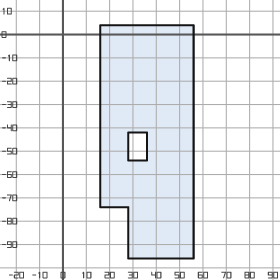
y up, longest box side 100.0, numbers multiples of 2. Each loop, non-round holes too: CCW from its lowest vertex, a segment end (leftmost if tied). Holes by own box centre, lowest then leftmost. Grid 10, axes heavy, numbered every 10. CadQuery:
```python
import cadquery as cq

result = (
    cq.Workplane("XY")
    .moveTo(28.0, -96.0)
    .lineTo(56.0, -96.0)
    .lineTo(56.0, 4.0)
    .lineTo(16.0, 4.0)
    .lineTo(16.0, -74.0)
    .lineTo(28.0, -74.0)
    .close()
    .moveTo(28.0, -54.0)
    .lineTo(36.0, -54.0)
    .lineTo(36.0, -42.0)
    .lineTo(28.0, -42.0)
    .close()
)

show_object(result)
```